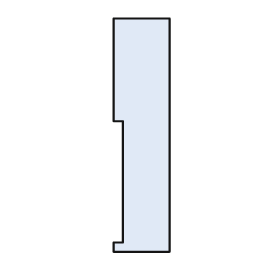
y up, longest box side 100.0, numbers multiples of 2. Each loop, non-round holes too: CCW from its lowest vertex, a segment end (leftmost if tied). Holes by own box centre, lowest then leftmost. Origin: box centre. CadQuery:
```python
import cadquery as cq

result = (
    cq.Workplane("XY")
    .moveTo(-12.0, -50.0)
    .lineTo(12.0, -50.0)
    .lineTo(12.0, 50.0)
    .lineTo(-12.0, 50.0)
    .lineTo(-12.0, 6.0)
    .lineTo(-8.0, 6.0)
    .lineTo(-8.0, -46.0)
    .lineTo(-12.0, -46.0)
    .close()
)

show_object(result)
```